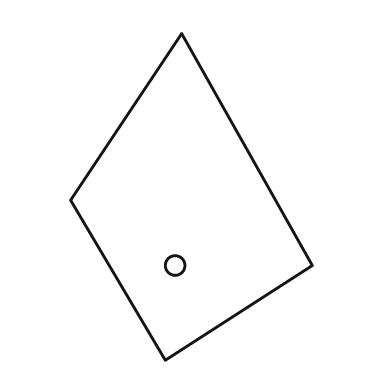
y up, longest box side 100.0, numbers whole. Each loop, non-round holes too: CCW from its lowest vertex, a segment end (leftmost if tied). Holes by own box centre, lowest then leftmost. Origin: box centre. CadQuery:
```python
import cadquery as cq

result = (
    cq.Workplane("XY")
    .moveTo(-8.0, -50.0)
    .lineTo(37.0, -21.0)
    .lineTo(-3.0, 50.0)
    .lineTo(-37.0, -1.0)
    .close()
    .moveTo(-5.0, -21.0)
    .circle(3.0)
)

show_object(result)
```